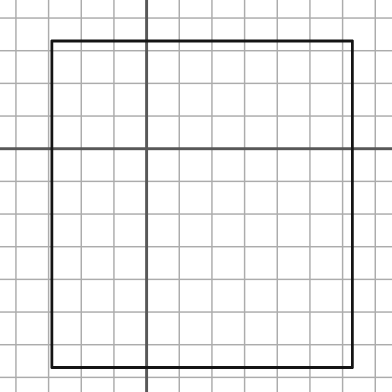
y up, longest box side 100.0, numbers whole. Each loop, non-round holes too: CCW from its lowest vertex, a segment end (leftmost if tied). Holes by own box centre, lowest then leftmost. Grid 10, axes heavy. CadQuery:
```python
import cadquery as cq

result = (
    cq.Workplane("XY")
    .moveTo(-29.0, -67.0)
    .lineTo(63.0, -67.0)
    .lineTo(63.0, 33.0)
    .lineTo(-29.0, 33.0)
    .close()
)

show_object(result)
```